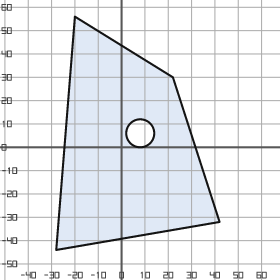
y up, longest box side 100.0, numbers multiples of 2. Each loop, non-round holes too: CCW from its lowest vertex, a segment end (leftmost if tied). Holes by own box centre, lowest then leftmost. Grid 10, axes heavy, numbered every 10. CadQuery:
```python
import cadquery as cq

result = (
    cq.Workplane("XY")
    .moveTo(-28.0, -44.0)
    .lineTo(42.0, -32.0)
    .lineTo(22.0, 30.0)
    .lineTo(-20.0, 56.0)
    .close()
    .moveTo(8.0, 6.0)
    .circle(6.0)
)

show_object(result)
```